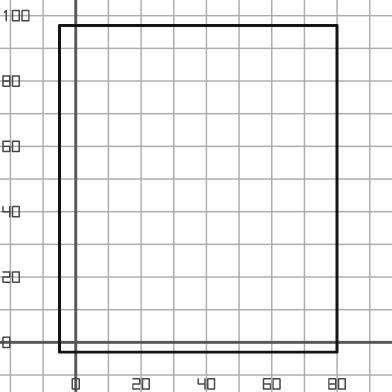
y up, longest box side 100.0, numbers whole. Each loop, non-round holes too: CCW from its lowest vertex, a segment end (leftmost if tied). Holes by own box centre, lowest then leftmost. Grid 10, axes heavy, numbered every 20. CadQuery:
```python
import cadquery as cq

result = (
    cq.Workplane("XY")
    .moveTo(-5.0, -3.0)
    .lineTo(80.0, -3.0)
    .lineTo(80.0, 97.0)
    .lineTo(-5.0, 97.0)
    .close()
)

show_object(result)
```